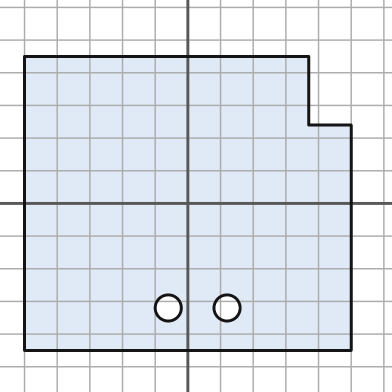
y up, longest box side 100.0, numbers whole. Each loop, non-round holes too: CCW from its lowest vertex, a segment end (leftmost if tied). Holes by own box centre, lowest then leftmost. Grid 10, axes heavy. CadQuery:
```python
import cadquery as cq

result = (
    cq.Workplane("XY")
    .moveTo(-50.0, -45.0)
    .lineTo(50.0, -45.0)
    .lineTo(50.0, 24.0)
    .lineTo(37.0, 24.0)
    .lineTo(37.0, 45.0)
    .lineTo(-50.0, 45.0)
    .close()
    .moveTo(-6.0, -32.0)
    .circle(4.0)
    .moveTo(12.0, -32.0)
    .circle(4.0)
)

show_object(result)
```